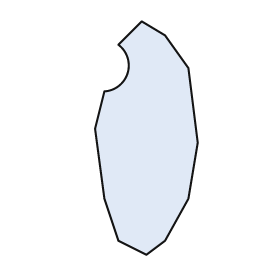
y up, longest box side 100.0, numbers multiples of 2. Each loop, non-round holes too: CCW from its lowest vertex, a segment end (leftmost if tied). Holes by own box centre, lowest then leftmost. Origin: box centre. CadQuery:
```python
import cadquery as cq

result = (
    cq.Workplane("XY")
    .moveTo(0.0, -50.0)
    .lineTo(8.0, -44.0)
    .lineTo(18.0, -26.0)
    .lineTo(22.0, -2.0)
    .lineTo(18.0, 30.0)
    .lineTo(8.0, 44.0)
    .lineTo(-2.0, 50.0)
    .lineTo(-12.0, 40.0)
    .threePointArc((-8.0, 28.0), (-18.0, 20.0))
    .lineTo(-22.0, 4.0)
    .lineTo(-18.0, -26.0)
    .lineTo(-12.0, -44.0)
    .close()
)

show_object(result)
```